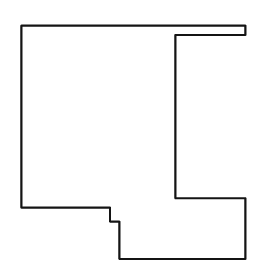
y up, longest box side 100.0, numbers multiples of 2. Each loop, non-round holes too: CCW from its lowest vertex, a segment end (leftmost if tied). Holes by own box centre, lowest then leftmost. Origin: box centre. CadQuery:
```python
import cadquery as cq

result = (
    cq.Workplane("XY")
    .moveTo(-6.0, -50.0)
    .lineTo(48.0, -50.0)
    .lineTo(48.0, -24.0)
    .lineTo(18.0, -24.0)
    .lineTo(18.0, 46.0)
    .lineTo(48.0, 46.0)
    .lineTo(48.0, 50.0)
    .lineTo(-48.0, 50.0)
    .lineTo(-48.0, -28.0)
    .lineTo(-10.0, -28.0)
    .lineTo(-10.0, -34.0)
    .lineTo(-6.0, -34.0)
    .close()
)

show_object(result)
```